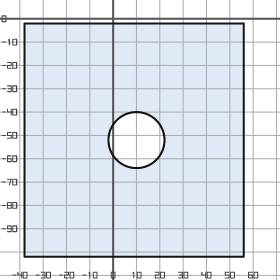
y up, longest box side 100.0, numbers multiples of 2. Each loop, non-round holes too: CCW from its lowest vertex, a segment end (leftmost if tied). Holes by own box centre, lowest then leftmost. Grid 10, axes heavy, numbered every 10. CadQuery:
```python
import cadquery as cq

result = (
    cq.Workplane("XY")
    .moveTo(-38.0, -102.0)
    .lineTo(56.0, -102.0)
    .lineTo(56.0, -2.0)
    .lineTo(-38.0, -2.0)
    .close()
    .moveTo(10.0, -52.0)
    .circle(12.0)
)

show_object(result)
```